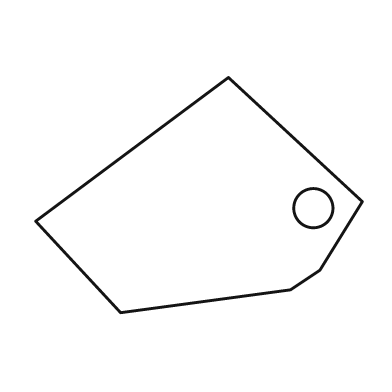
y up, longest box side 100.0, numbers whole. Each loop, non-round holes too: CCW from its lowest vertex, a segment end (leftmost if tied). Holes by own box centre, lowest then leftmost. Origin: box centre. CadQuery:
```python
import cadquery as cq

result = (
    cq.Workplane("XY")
    .moveTo(-24.0, -36.0)
    .lineTo(28.0, -29.0)
    .lineTo(37.0, -23.0)
    .lineTo(50.0, -2.0)
    .lineTo(9.0, 36.0)
    .lineTo(-50.0, -8.0)
    .close()
    .moveTo(35.0, -4.0)
    .circle(6.0)
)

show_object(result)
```